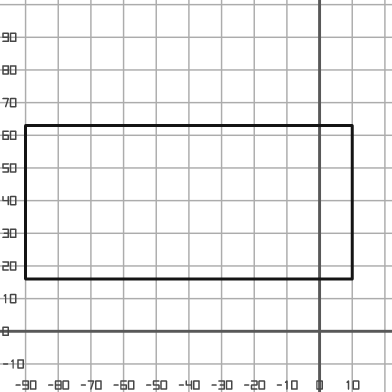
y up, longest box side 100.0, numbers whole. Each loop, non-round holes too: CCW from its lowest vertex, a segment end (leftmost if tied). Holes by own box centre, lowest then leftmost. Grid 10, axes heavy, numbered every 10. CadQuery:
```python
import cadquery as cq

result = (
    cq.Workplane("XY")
    .moveTo(-90.0, 16.0)
    .lineTo(10.0, 16.0)
    .lineTo(10.0, 63.0)
    .lineTo(-90.0, 63.0)
    .close()
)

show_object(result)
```